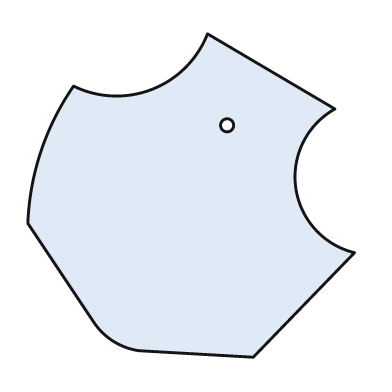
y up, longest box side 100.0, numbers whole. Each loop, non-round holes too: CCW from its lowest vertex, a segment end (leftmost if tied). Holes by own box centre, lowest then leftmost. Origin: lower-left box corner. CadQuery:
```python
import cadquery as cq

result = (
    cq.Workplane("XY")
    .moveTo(69.0, 0.0)
    .lineTo(100.0, 32.0)
    .threePointArc((82.0, 52.0), (94.0, 76.0))
    .lineTo(55.0, 99.0)
    .threePointArc((38.0, 82.0), (14.0, 83.0))
    .threePointArc((4.0, 63.0), (0.0, 41.0))
    .lineTo(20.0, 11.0)
    .threePointArc((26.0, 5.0), (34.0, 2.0))
    .close()
    .moveTo(61.0, 71.0)
    .circle(2.0)
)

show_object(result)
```